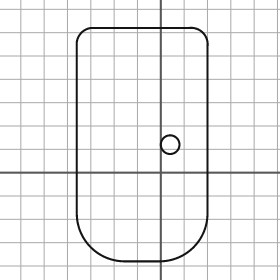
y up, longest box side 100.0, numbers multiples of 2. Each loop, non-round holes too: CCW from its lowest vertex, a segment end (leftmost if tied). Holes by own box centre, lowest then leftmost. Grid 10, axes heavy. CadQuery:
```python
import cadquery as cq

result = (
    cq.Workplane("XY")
    .moveTo(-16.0, -38.0)
    .lineTo(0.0, -38.0)
    .threePointArc((14.0, -32.0), (20.0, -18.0))
    .lineTo(20.0, 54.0)
    .threePointArc((18.0, 60.0), (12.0, 62.0))
    .lineTo(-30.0, 62.0)
    .threePointArc((-34.0, 60.0), (-36.0, 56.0))
    .lineTo(-36.0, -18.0)
    .threePointArc((-30.0, -32.0), (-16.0, -38.0))
    .close()
    .moveTo(4.0, 12.0)
    .circle(4.0)
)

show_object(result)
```